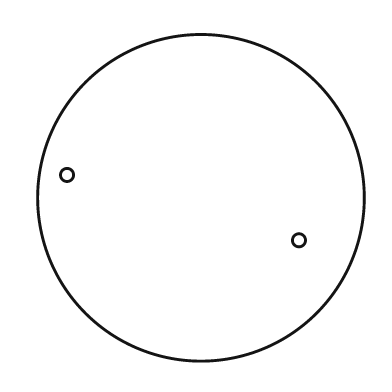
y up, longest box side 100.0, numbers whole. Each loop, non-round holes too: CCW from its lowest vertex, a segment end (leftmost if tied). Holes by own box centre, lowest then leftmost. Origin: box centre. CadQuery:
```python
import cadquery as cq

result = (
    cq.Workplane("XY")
    .moveTo(0.0, 0.0)
    .circle(50.0)
    .moveTo(30.0, -13.0)
    .circle(2.0)
    .moveTo(-41.0, 7.0)
    .circle(2.0)
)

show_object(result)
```